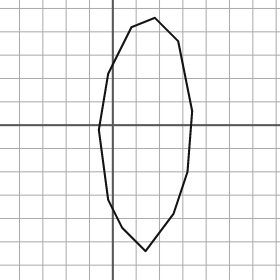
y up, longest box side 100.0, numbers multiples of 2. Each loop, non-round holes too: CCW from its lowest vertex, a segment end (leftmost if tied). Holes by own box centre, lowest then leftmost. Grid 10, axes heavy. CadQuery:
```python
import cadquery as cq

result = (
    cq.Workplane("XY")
    .moveTo(14.0, -54.0)
    .lineTo(26.0, -38.0)
    .lineTo(32.0, -20.0)
    .lineTo(34.0, 6.0)
    .lineTo(28.0, 36.0)
    .lineTo(18.0, 46.0)
    .lineTo(8.0, 42.0)
    .lineTo(-2.0, 22.0)
    .lineTo(-6.0, -2.0)
    .lineTo(-2.0, -32.0)
    .lineTo(4.0, -44.0)
    .close()
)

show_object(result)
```